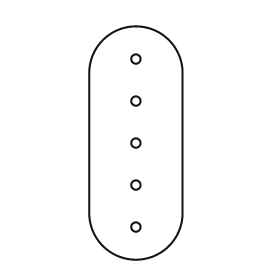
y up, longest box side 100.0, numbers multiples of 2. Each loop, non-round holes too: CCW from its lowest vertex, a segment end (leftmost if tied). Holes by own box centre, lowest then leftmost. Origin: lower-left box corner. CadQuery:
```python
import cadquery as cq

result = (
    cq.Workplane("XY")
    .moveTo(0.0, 20.0)
    .threePointArc((20.0, 0.0), (40.0, 20.0))
    .lineTo(40.0, 80.0)
    .threePointArc((20.0, 100.0), (0.0, 80.0))
    .close()
    .moveTo(20.0, 14.0)
    .circle(2.0)
    .moveTo(20.0, 32.0)
    .circle(2.0)
    .moveTo(20.0, 50.0)
    .circle(2.0)
    .moveTo(20.0, 68.0)
    .circle(2.0)
    .moveTo(20.0, 86.0)
    .circle(2.0)
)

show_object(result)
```